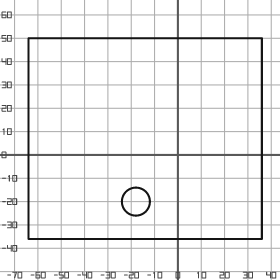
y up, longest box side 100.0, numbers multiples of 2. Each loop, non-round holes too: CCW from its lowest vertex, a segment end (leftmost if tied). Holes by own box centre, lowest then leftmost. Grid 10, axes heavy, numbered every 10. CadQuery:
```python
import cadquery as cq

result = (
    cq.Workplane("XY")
    .moveTo(-64.0, -36.0)
    .lineTo(36.0, -36.0)
    .lineTo(36.0, 50.0)
    .lineTo(-64.0, 50.0)
    .close()
    .moveTo(-18.0, -20.0)
    .circle(6.0)
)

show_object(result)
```